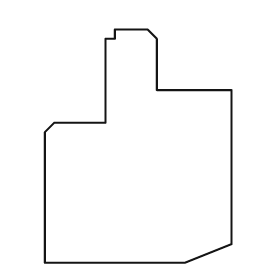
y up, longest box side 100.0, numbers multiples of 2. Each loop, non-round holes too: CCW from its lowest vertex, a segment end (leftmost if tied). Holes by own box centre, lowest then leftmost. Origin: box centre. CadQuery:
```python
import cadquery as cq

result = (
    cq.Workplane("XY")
    .moveTo(-40.0, -50.0)
    .lineTo(20.0, -50.0)
    .lineTo(40.0, -42.0)
    .lineTo(40.0, 24.0)
    .lineTo(8.0, 24.0)
    .lineTo(8.0, 46.0)
    .lineTo(4.0, 50.0)
    .lineTo(-10.0, 50.0)
    .lineTo(-10.0, 46.0)
    .lineTo(-14.0, 46.0)
    .lineTo(-14.0, 10.0)
    .lineTo(-36.0, 10.0)
    .lineTo(-40.0, 6.0)
    .close()
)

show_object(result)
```